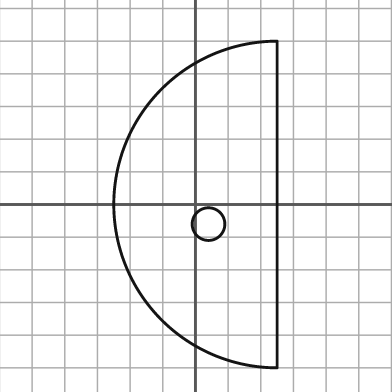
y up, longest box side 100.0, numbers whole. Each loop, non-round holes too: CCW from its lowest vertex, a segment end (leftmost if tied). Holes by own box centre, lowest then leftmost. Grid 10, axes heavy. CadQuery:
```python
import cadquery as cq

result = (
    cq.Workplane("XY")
    .moveTo(25.0, -50.0)
    .lineTo(25.0, 50.0)
    .threePointArc((-25.0, 0.0), (25.0, -50.0))
    .close()
    .moveTo(4.0, -6.0)
    .circle(5.0)
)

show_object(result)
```